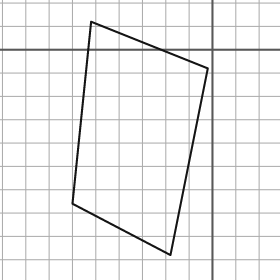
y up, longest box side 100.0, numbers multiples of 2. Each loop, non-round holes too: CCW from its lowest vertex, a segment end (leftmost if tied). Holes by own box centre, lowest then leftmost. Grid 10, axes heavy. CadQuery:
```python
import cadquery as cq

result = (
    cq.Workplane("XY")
    .moveTo(-18.0, -88.0)
    .lineTo(-2.0, -8.0)
    .lineTo(-52.0, 12.0)
    .lineTo(-60.0, -66.0)
    .close()
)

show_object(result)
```